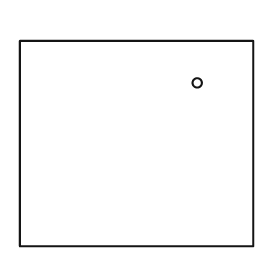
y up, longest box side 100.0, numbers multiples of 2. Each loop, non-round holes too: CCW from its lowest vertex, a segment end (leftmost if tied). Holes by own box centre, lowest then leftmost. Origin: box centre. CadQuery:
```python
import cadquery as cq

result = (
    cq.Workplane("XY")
    .moveTo(-50.0, -44.0)
    .lineTo(50.0, -44.0)
    .lineTo(50.0, 44.0)
    .lineTo(-50.0, 44.0)
    .close()
    .moveTo(26.0, 26.0)
    .circle(2.0)
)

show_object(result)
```